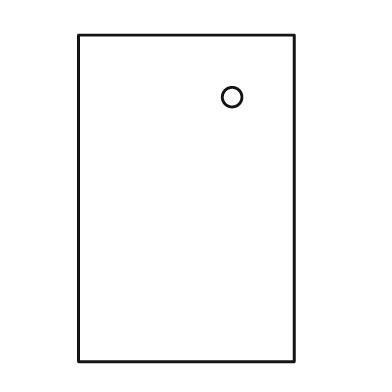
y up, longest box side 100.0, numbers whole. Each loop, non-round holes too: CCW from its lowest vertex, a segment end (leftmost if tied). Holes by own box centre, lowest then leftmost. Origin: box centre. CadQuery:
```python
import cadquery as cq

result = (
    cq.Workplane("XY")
    .moveTo(-33.0, -50.0)
    .lineTo(33.0, -50.0)
    .lineTo(33.0, 50.0)
    .lineTo(-33.0, 50.0)
    .close()
    .moveTo(14.0, 31.0)
    .circle(3.0)
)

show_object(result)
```